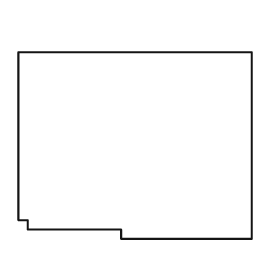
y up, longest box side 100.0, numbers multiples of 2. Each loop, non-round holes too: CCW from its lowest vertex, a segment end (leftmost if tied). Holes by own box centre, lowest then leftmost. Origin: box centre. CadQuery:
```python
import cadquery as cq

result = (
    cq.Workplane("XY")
    .moveTo(-6.0, -40.0)
    .lineTo(50.0, -40.0)
    .lineTo(50.0, 40.0)
    .lineTo(-50.0, 40.0)
    .lineTo(-50.0, -32.0)
    .lineTo(-46.0, -32.0)
    .lineTo(-46.0, -36.0)
    .lineTo(-6.0, -36.0)
    .close()
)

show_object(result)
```